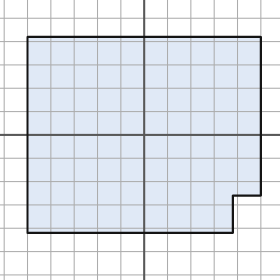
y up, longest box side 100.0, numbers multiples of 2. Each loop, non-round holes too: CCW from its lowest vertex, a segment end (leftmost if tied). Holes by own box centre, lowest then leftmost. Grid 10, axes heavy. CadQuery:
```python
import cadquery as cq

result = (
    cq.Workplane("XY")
    .moveTo(-50.0, -42.0)
    .lineTo(38.0, -42.0)
    .lineTo(38.0, -26.0)
    .lineTo(50.0, -26.0)
    .lineTo(50.0, 42.0)
    .lineTo(-50.0, 42.0)
    .close()
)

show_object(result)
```